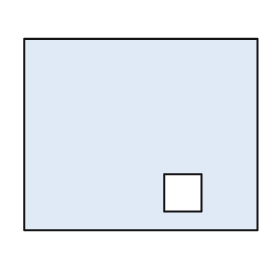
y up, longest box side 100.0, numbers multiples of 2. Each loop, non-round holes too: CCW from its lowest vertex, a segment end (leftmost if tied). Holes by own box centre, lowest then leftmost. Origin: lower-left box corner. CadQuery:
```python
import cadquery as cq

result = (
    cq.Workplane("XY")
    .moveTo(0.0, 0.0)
    .lineTo(100.0, 0.0)
    .lineTo(100.0, 82.0)
    .lineTo(0.0, 82.0)
    .close()
    .moveTo(60.0, 8.0)
    .lineTo(76.0, 8.0)
    .lineTo(76.0, 24.0)
    .lineTo(60.0, 24.0)
    .close()
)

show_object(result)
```